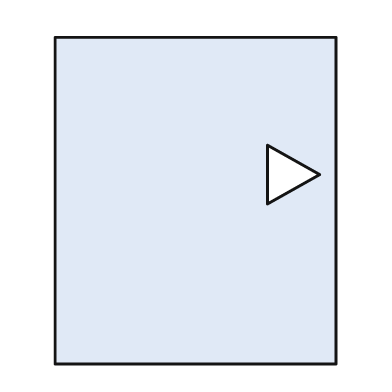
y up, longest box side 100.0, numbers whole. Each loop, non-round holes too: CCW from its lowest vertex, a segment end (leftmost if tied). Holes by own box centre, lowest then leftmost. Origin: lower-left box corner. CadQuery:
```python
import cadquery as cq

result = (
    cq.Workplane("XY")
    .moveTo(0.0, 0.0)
    .lineTo(86.0, 0.0)
    .lineTo(86.0, 100.0)
    .lineTo(0.0, 100.0)
    .close()
    .moveTo(65.0, 49.0)
    .lineTo(81.0, 58.0)
    .lineTo(65.0, 67.0)
    .close()
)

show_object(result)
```